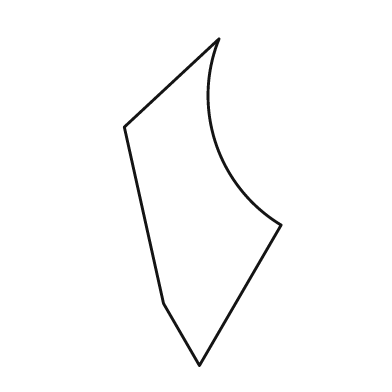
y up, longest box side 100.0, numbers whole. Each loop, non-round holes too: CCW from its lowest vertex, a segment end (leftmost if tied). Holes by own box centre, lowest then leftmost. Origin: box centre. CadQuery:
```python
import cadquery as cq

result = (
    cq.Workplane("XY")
    .moveTo(-1.0, -50.0)
    .lineTo(24.0, -7.0)
    .threePointArc((4.0, 18.0), (5.0, 50.0))
    .lineTo(-24.0, 23.0)
    .lineTo(-12.0, -31.0)
    .close()
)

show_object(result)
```